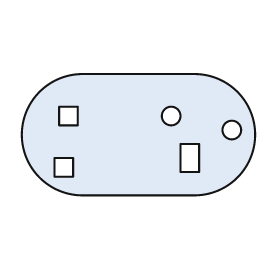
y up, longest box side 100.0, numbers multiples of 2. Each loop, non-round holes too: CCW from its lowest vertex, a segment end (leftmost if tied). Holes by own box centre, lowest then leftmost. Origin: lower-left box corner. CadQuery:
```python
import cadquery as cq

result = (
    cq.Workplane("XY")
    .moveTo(26.0, 0.0)
    .lineTo(74.0, 0.0)
    .threePointArc((100.0, 26.0), (74.0, 52.0))
    .lineTo(26.0, 52.0)
    .threePointArc((0.0, 26.0), (26.0, 0.0))
    .close()
    .moveTo(14.0, 8.0)
    .lineTo(22.0, 8.0)
    .lineTo(22.0, 16.0)
    .lineTo(14.0, 16.0)
    .close()
    .moveTo(68.0, 10.0)
    .lineTo(76.0, 10.0)
    .lineTo(76.0, 22.0)
    .lineTo(68.0, 22.0)
    .close()
    .moveTo(90.0, 28.0)
    .circle(4.0)
    .moveTo(16.0, 30.0)
    .lineTo(24.0, 30.0)
    .lineTo(24.0, 38.0)
    .lineTo(16.0, 38.0)
    .close()
    .moveTo(64.0, 34.0)
    .circle(4.0)
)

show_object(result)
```